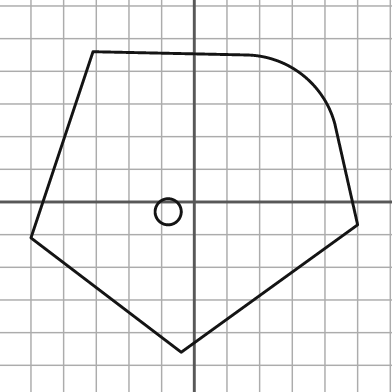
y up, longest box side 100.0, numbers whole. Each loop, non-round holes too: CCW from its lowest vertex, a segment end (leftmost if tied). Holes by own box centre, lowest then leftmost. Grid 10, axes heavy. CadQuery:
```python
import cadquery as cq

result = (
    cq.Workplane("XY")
    .moveTo(-4.0, -46.0)
    .lineTo(50.0, -7.0)
    .lineTo(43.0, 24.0)
    .threePointArc((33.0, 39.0), (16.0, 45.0))
    .lineTo(-31.0, 46.0)
    .lineTo(-50.0, -11.0)
    .close()
    .moveTo(-8.0, -3.0)
    .circle(4.0)
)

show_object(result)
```